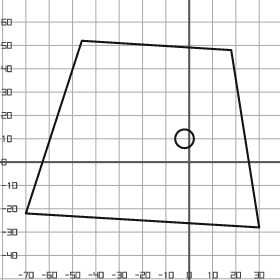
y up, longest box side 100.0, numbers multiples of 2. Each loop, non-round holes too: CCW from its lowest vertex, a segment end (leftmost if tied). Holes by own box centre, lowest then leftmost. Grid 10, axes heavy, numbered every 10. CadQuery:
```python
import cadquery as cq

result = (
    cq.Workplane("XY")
    .moveTo(30.0, -28.0)
    .lineTo(18.0, 48.0)
    .lineTo(-46.0, 52.0)
    .lineTo(-70.0, -22.0)
    .close()
    .moveTo(-2.0, 10.0)
    .circle(4.0)
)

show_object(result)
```